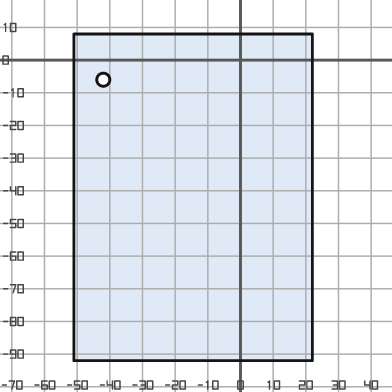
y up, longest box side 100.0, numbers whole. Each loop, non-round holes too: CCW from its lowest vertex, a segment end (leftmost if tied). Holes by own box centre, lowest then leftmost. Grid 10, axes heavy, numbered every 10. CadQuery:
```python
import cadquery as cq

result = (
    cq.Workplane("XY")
    .moveTo(-51.0, -92.0)
    .lineTo(22.0, -92.0)
    .lineTo(22.0, 8.0)
    .lineTo(-51.0, 8.0)
    .close()
    .moveTo(-42.0, -6.0)
    .circle(2.0)
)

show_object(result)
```